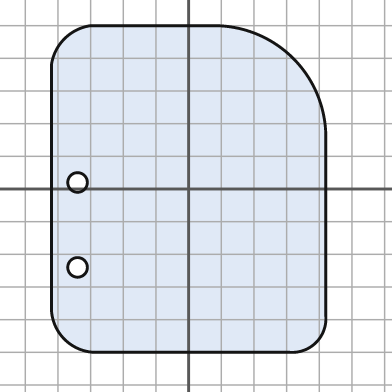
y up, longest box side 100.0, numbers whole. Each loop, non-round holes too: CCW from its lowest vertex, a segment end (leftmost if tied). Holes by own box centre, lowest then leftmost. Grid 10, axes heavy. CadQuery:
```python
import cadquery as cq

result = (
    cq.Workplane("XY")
    .moveTo(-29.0, -50.0)
    .lineTo(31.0, -50.0)
    .threePointArc((39.0, -47.0), (42.0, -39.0))
    .lineTo(42.0, 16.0)
    .threePointArc((32.0, 40.0), (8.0, 50.0))
    .lineTo(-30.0, 50.0)
    .threePointArc((-38.0, 46.0), (-42.0, 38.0))
    .lineTo(-42.0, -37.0)
    .threePointArc((-38.0, -46.0), (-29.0, -50.0))
    .close()
    .moveTo(-34.0, -24.0)
    .circle(3.0)
    .moveTo(-34.0, 2.0)
    .circle(3.0)
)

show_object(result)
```